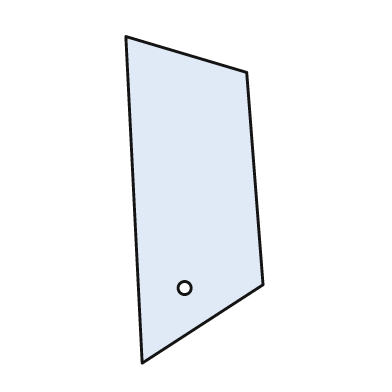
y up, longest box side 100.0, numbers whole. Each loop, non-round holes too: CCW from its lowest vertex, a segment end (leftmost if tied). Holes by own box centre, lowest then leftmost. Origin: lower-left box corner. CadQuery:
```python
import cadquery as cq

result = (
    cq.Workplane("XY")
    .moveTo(5.0, 0.0)
    .lineTo(42.0, 24.0)
    .lineTo(37.0, 89.0)
    .lineTo(0.0, 100.0)
    .close()
    .moveTo(18.0, 23.0)
    .circle(2.0)
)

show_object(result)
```